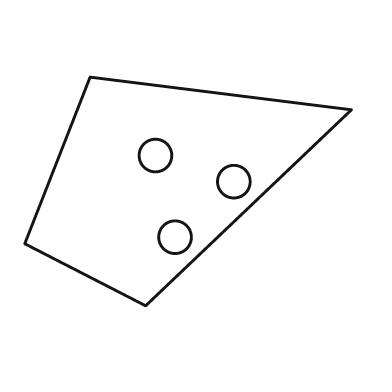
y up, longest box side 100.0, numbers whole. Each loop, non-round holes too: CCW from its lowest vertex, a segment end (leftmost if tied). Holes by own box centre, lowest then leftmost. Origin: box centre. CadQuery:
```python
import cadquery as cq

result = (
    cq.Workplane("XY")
    .moveTo(-13.0, -35.0)
    .lineTo(50.0, 25.0)
    .lineTo(-30.0, 35.0)
    .lineTo(-50.0, -16.0)
    .close()
    .moveTo(-4.0, -14.0)
    .circle(5.0)
    .moveTo(14.0, 3.0)
    .circle(5.0)
    .moveTo(-10.0, 11.0)
    .circle(5.0)
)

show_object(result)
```